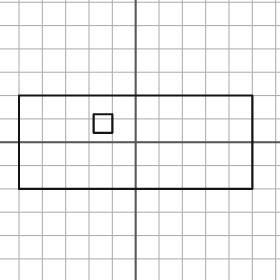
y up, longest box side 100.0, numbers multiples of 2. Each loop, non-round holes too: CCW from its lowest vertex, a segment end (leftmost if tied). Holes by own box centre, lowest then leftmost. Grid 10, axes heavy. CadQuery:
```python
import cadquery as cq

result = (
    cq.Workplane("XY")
    .moveTo(-50.0, -20.0)
    .lineTo(50.0, -20.0)
    .lineTo(50.0, 20.0)
    .lineTo(-50.0, 20.0)
    .close()
    .moveTo(-18.0, 4.0)
    .lineTo(-10.0, 4.0)
    .lineTo(-10.0, 12.0)
    .lineTo(-18.0, 12.0)
    .close()
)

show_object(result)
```